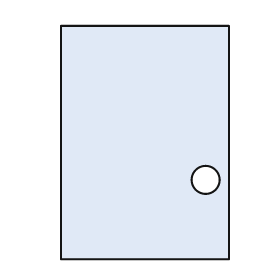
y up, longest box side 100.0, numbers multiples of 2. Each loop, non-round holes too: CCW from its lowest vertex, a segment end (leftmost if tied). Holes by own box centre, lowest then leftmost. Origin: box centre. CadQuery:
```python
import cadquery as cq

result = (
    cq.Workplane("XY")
    .moveTo(-36.0, -50.0)
    .lineTo(36.0, -50.0)
    .lineTo(36.0, 50.0)
    .lineTo(-36.0, 50.0)
    .close()
    .moveTo(26.0, -16.0)
    .circle(6.0)
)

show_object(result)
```